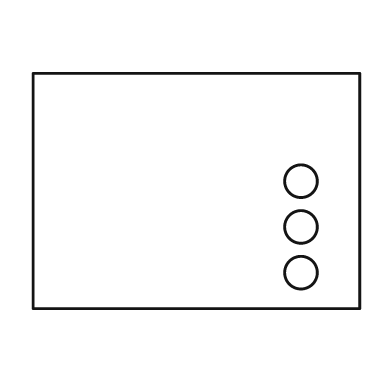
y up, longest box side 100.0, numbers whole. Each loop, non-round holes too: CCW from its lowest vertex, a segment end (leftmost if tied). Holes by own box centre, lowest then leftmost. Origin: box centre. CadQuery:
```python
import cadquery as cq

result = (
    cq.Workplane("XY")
    .moveTo(-50.0, -36.0)
    .lineTo(50.0, -36.0)
    .lineTo(50.0, 36.0)
    .lineTo(-50.0, 36.0)
    .close()
    .moveTo(32.0, -25.0)
    .circle(5.0)
    .moveTo(32.0, -11.0)
    .circle(5.0)
    .moveTo(32.0, 3.0)
    .circle(5.0)
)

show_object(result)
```